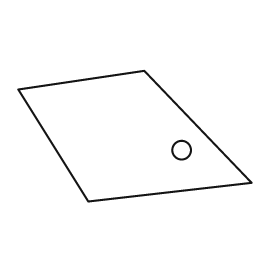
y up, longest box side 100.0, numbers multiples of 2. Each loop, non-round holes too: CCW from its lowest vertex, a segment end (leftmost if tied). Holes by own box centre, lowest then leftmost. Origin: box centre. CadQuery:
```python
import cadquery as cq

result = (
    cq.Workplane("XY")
    .moveTo(-20.0, -28.0)
    .lineTo(50.0, -20.0)
    .lineTo(4.0, 28.0)
    .lineTo(-50.0, 20.0)
    .close()
    .moveTo(20.0, -6.0)
    .circle(4.0)
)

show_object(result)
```